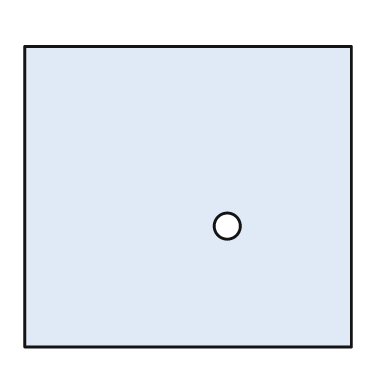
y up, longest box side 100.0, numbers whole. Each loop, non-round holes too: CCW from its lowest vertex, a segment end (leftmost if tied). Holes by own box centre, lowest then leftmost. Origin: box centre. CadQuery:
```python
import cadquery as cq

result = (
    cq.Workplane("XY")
    .moveTo(-50.0, -46.0)
    .lineTo(50.0, -46.0)
    .lineTo(50.0, 46.0)
    .lineTo(-50.0, 46.0)
    .close()
    .moveTo(12.0, -9.0)
    .circle(4.0)
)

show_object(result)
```